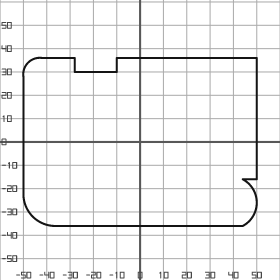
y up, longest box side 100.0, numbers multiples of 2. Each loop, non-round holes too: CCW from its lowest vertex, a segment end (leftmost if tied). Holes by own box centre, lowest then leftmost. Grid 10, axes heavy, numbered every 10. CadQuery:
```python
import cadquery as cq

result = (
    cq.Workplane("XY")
    .moveTo(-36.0, -36.0)
    .lineTo(44.0, -36.0)
    .threePointArc((50.0, -26.0), (44.0, -16.0))
    .lineTo(50.0, -16.0)
    .lineTo(50.0, 36.0)
    .lineTo(-10.0, 36.0)
    .lineTo(-10.0, 30.0)
    .lineTo(-28.0, 30.0)
    .lineTo(-28.0, 36.0)
    .lineTo(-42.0, 36.0)
    .threePointArc((-48.0, 34.0), (-50.0, 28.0))
    .lineTo(-50.0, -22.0)
    .threePointArc((-46.0, -32.0), (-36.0, -36.0))
    .close()
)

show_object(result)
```